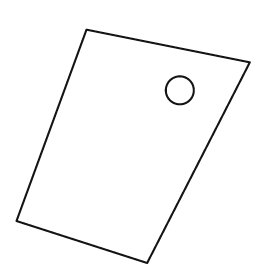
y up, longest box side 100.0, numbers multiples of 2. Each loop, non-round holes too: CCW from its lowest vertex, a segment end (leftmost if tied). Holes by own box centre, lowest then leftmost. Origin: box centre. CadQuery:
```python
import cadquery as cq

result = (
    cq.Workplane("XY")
    .moveTo(6.0, -50.0)
    .lineTo(50.0, 36.0)
    .lineTo(-20.0, 50.0)
    .lineTo(-50.0, -32.0)
    .close()
    .moveTo(20.0, 24.0)
    .circle(6.0)
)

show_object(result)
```